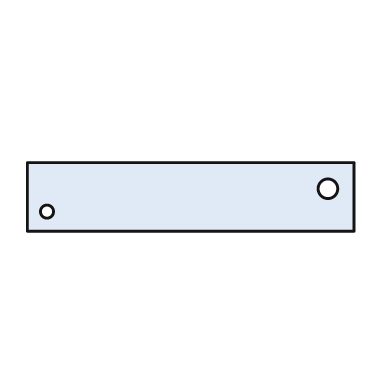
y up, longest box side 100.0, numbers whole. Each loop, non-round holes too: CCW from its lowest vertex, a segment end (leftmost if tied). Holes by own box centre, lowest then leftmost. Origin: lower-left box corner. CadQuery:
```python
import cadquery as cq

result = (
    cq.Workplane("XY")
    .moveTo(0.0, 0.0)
    .lineTo(100.0, 0.0)
    .lineTo(100.0, 21.0)
    .lineTo(0.0, 21.0)
    .close()
    .moveTo(6.0, 6.0)
    .circle(2.0)
    .moveTo(92.0, 13.0)
    .circle(3.0)
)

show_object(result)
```